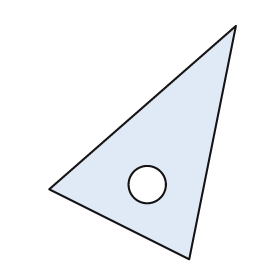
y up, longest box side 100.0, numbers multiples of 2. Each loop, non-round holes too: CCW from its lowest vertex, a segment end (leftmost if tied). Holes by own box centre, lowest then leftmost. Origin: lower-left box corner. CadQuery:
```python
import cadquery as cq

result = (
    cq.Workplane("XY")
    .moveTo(60.0, 0.0)
    .lineTo(80.0, 100.0)
    .lineTo(0.0, 30.0)
    .close()
    .moveTo(42.0, 32.0)
    .circle(8.0)
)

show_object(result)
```